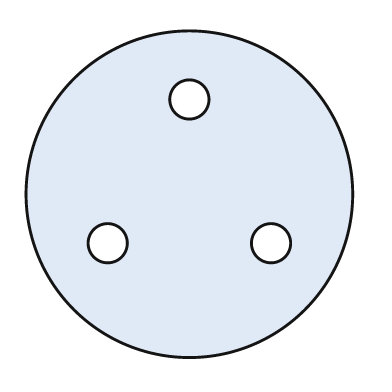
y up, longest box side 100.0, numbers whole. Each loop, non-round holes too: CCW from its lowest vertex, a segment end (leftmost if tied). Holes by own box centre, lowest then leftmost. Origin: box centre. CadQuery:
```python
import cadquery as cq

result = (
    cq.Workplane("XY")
    .moveTo(0.0, 0.0)
    .circle(50.0)
    .moveTo(-25.0, -15.0)
    .circle(6.0)
    .moveTo(25.0, -15.0)
    .circle(6.0)
    .moveTo(0.0, 29.0)
    .circle(6.0)
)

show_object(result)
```